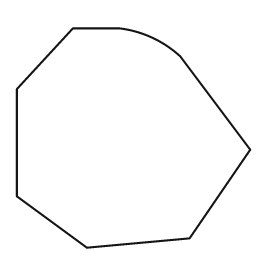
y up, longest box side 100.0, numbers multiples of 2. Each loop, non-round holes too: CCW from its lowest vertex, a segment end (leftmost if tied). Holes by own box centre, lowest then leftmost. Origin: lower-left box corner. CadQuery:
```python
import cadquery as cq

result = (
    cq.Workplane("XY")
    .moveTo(30.0, 0.0)
    .lineTo(74.0, 4.0)
    .lineTo(100.0, 42.0)
    .lineTo(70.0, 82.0)
    .threePointArc((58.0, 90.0), (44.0, 94.0))
    .lineTo(24.0, 94.0)
    .lineTo(0.0, 68.0)
    .lineTo(0.0, 22.0)
    .close()
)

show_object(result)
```